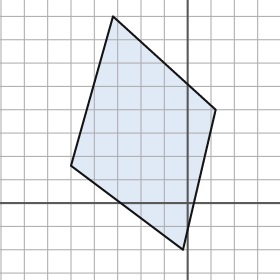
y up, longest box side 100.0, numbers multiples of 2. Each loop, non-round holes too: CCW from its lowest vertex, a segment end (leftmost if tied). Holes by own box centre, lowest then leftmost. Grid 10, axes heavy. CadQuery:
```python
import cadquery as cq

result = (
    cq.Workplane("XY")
    .moveTo(-2.0, -20.0)
    .lineTo(12.0, 40.0)
    .lineTo(-32.0, 80.0)
    .lineTo(-50.0, 16.0)
    .close()
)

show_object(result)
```